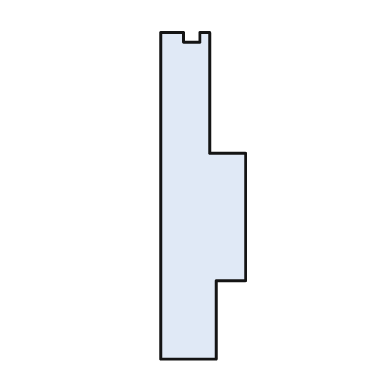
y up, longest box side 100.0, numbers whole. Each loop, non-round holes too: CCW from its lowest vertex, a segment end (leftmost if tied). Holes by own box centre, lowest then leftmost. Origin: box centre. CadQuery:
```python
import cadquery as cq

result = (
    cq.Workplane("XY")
    .moveTo(-13.0, -50.0)
    .lineTo(4.0, -50.0)
    .lineTo(4.0, -26.0)
    .lineTo(13.0, -26.0)
    .lineTo(13.0, 13.0)
    .lineTo(2.0, 13.0)
    .lineTo(2.0, 50.0)
    .lineTo(-1.0, 50.0)
    .lineTo(-1.0, 47.0)
    .lineTo(-6.0, 47.0)
    .lineTo(-6.0, 50.0)
    .lineTo(-13.0, 50.0)
    .close()
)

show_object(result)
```